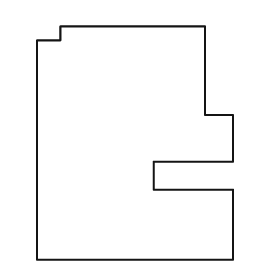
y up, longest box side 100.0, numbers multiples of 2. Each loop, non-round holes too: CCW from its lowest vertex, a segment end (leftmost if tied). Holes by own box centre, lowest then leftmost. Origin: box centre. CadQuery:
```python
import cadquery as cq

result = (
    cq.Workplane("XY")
    .moveTo(-42.0, -50.0)
    .lineTo(42.0, -50.0)
    .lineTo(42.0, -20.0)
    .lineTo(8.0, -20.0)
    .lineTo(8.0, -8.0)
    .lineTo(42.0, -8.0)
    .lineTo(42.0, 12.0)
    .lineTo(30.0, 12.0)
    .lineTo(30.0, 50.0)
    .lineTo(-32.0, 50.0)
    .lineTo(-32.0, 44.0)
    .lineTo(-42.0, 44.0)
    .close()
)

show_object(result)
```